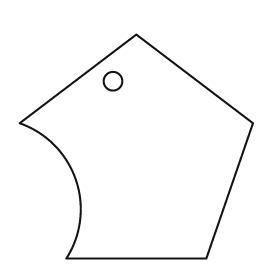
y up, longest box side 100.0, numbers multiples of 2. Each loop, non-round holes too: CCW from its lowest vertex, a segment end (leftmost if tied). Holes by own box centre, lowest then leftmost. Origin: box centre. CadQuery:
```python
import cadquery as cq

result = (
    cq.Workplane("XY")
    .moveTo(-30.0, -48.0)
    .lineTo(30.0, -48.0)
    .lineTo(50.0, 10.0)
    .lineTo(0.0, 48.0)
    .lineTo(-50.0, 10.0)
    .threePointArc((-26.0, -14.0), (-30.0, -48.0))
    .close()
    .moveTo(-10.0, 28.0)
    .circle(4.0)
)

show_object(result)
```